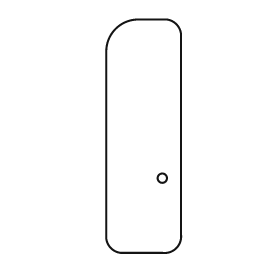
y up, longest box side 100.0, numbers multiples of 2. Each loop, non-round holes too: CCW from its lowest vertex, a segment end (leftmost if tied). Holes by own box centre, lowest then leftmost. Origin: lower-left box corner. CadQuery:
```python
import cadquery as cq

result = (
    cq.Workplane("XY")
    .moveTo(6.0, 0.0)
    .lineTo(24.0, 0.0)
    .threePointArc((30.0, 2.0), (32.0, 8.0))
    .lineTo(32.0, 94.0)
    .threePointArc((30.0, 98.0), (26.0, 100.0))
    .lineTo(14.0, 100.0)
    .threePointArc((4.0, 96.0), (0.0, 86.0))
    .lineTo(0.0, 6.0)
    .threePointArc((2.0, 2.0), (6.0, 0.0))
    .close()
    .moveTo(24.0, 32.0)
    .circle(2.0)
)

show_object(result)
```